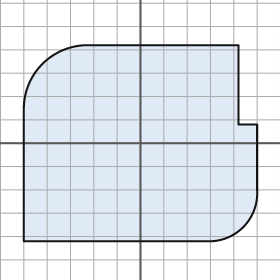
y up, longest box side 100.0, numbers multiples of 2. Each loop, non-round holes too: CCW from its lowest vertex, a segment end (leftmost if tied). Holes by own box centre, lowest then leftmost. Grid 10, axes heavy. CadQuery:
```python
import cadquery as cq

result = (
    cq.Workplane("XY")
    .moveTo(-50.0, -42.0)
    .lineTo(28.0, -42.0)
    .threePointArc((44.0, -36.0), (50.0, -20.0))
    .lineTo(50.0, 8.0)
    .lineTo(42.0, 8.0)
    .lineTo(42.0, 42.0)
    .lineTo(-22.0, 42.0)
    .threePointArc((-42.0, 34.0), (-50.0, 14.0))
    .close()
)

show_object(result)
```